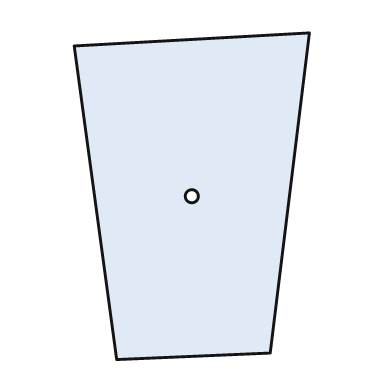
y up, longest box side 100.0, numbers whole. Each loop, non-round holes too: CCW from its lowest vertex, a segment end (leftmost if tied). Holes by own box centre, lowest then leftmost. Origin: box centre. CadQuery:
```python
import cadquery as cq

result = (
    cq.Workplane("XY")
    .moveTo(-23.0, -50.0)
    .lineTo(24.0, -48.0)
    .lineTo(36.0, 50.0)
    .lineTo(-36.0, 46.0)
    .close()
    .moveTo(0.0, 0.0)
    .circle(2.0)
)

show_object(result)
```